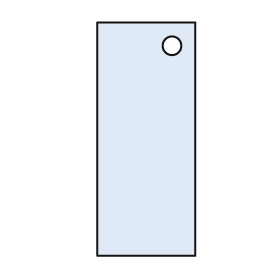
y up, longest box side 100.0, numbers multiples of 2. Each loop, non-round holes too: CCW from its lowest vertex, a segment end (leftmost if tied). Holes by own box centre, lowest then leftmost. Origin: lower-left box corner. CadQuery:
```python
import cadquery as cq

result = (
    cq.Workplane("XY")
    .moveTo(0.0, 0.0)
    .lineTo(42.0, 0.0)
    .lineTo(42.0, 100.0)
    .lineTo(0.0, 100.0)
    .close()
    .moveTo(32.0, 90.0)
    .circle(4.0)
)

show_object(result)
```